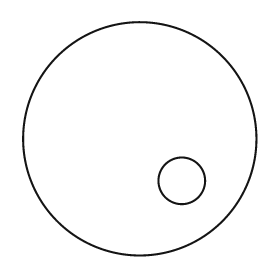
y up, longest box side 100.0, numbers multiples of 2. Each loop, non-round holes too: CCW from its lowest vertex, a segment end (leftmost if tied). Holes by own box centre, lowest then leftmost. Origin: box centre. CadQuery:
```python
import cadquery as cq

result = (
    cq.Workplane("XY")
    .moveTo(0.0, 0.0)
    .circle(50.0)
    .moveTo(18.0, -18.0)
    .circle(10.0)
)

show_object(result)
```